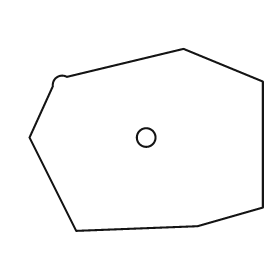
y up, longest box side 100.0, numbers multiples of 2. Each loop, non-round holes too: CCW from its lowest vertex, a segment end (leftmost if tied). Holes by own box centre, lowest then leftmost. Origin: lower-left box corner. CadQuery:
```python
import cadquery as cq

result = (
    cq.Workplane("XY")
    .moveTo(20.0, 0.0)
    .lineTo(72.0, 2.0)
    .lineTo(100.0, 10.0)
    .lineTo(100.0, 64.0)
    .lineTo(66.0, 78.0)
    .lineTo(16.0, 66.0)
    .threePointArc((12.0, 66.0), (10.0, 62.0))
    .lineTo(0.0, 40.0)
    .close()
    .moveTo(50.0, 40.0)
    .circle(4.0)
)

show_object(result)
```